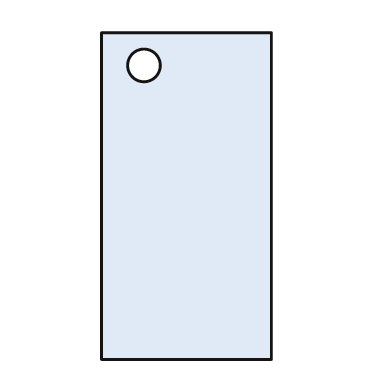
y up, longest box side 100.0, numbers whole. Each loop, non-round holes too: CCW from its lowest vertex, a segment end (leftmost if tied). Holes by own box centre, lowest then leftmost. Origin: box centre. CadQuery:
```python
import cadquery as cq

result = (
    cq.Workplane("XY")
    .moveTo(-26.0, -50.0)
    .lineTo(26.0, -50.0)
    .lineTo(26.0, 50.0)
    .lineTo(-26.0, 50.0)
    .close()
    .moveTo(-13.0, 40.0)
    .circle(5.0)
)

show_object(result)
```